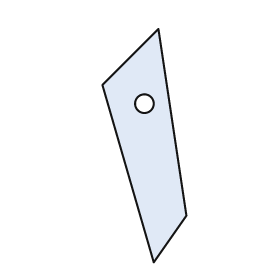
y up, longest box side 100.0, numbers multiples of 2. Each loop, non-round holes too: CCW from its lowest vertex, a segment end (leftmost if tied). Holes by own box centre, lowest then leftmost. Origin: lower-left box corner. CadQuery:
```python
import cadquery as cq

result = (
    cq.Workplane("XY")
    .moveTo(22.0, 0.0)
    .lineTo(36.0, 20.0)
    .lineTo(24.0, 100.0)
    .lineTo(0.0, 76.0)
    .close()
    .moveTo(18.0, 68.0)
    .circle(4.0)
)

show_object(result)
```